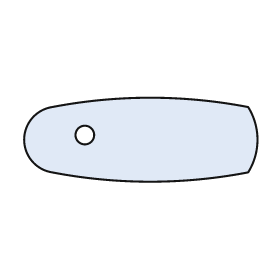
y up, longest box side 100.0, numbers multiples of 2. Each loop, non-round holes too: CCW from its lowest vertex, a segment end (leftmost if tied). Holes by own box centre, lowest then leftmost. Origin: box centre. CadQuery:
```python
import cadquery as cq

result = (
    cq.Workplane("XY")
    .moveTo(-38.0, -14.0)
    .threePointArc((4.0, -18.0), (46.0, -14.0))
    .threePointArc((50.0, 0.0), (46.0, 14.0))
    .threePointArc((4.0, 18.0), (-38.0, 14.0))
    .threePointArc((-50.0, 0.0), (-38.0, -14.0))
    .close()
    .moveTo(-24.0, 2.0)
    .circle(4.0)
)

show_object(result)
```